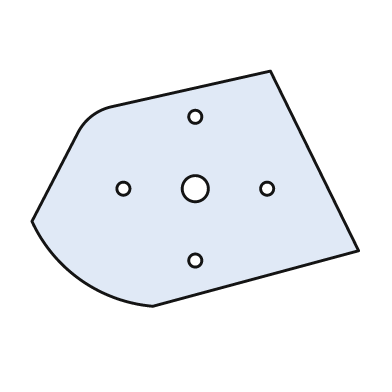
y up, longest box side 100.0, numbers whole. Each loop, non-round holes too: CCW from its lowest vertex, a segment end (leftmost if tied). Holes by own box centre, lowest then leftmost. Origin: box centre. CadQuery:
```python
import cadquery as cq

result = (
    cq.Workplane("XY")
    .moveTo(-13.0, -36.0)
    .lineTo(50.0, -19.0)
    .lineTo(23.0, 36.0)
    .lineTo(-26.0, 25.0)
    .threePointArc((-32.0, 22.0), (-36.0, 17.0))
    .lineTo(-50.0, -10.0)
    .threePointArc((-35.0, -28.0), (-13.0, -36.0))
    .close()
    .moveTo(0.0, -22.0)
    .circle(2.0)
    .moveTo(-22.0, 0.0)
    .circle(2.0)
    .moveTo(0.0, 0.0)
    .circle(4.0)
    .moveTo(22.0, 0.0)
    .circle(2.0)
    .moveTo(0.0, 22.0)
    .circle(2.0)
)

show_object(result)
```